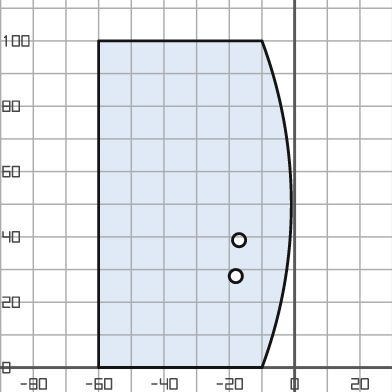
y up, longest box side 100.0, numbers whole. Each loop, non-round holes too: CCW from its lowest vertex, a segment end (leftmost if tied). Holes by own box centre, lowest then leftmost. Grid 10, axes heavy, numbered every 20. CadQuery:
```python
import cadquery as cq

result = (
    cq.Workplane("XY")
    .moveTo(-60.0, 0.0)
    .lineTo(-10.0, 0.0)
    .threePointArc((-1.0, 50.0), (-10.0, 100.0))
    .lineTo(-60.0, 100.0)
    .close()
    .moveTo(-18.0, 28.0)
    .circle(2.0)
    .moveTo(-17.0, 39.0)
    .circle(2.0)
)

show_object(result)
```